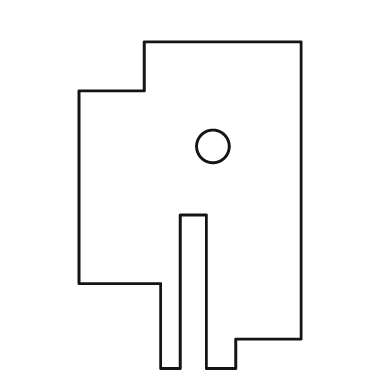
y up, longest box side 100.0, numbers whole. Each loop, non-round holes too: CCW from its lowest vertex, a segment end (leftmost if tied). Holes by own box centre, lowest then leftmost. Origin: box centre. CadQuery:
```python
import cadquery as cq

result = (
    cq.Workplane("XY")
    .moveTo(-9.0, -50.0)
    .lineTo(-3.0, -50.0)
    .lineTo(-3.0, -3.0)
    .lineTo(5.0, -3.0)
    .lineTo(5.0, -50.0)
    .lineTo(14.0, -50.0)
    .lineTo(14.0, -41.0)
    .lineTo(34.0, -41.0)
    .lineTo(34.0, 50.0)
    .lineTo(-14.0, 50.0)
    .lineTo(-14.0, 35.0)
    .lineTo(-34.0, 35.0)
    .lineTo(-34.0, -24.0)
    .lineTo(-9.0, -24.0)
    .close()
    .moveTo(7.0, 18.0)
    .circle(5.0)
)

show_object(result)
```